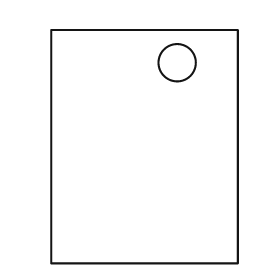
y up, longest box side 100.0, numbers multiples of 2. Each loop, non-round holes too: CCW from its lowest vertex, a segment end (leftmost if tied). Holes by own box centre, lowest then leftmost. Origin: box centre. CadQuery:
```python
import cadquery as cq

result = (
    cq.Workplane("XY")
    .moveTo(-40.0, -50.0)
    .lineTo(40.0, -50.0)
    .lineTo(40.0, 50.0)
    .lineTo(-40.0, 50.0)
    .close()
    .moveTo(14.0, 36.0)
    .circle(8.0)
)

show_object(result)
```